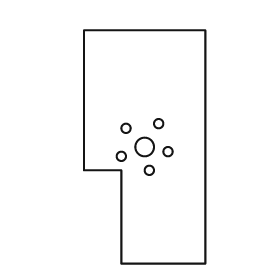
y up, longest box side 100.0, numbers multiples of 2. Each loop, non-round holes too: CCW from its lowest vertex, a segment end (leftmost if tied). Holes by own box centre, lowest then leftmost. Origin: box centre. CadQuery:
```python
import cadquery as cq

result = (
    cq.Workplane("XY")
    .moveTo(-10.0, -50.0)
    .lineTo(26.0, -50.0)
    .lineTo(26.0, 50.0)
    .lineTo(-26.0, 50.0)
    .lineTo(-26.0, -10.0)
    .lineTo(-10.0, -10.0)
    .close()
    .moveTo(2.0, -10.0)
    .circle(2.0)
    .moveTo(-10.0, -4.0)
    .circle(2.0)
    .moveTo(10.0, -2.0)
    .circle(2.0)
    .moveTo(0.0, 0.0)
    .circle(4.0)
    .moveTo(-8.0, 8.0)
    .circle(2.0)
    .moveTo(6.0, 10.0)
    .circle(2.0)
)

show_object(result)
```